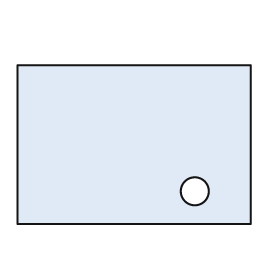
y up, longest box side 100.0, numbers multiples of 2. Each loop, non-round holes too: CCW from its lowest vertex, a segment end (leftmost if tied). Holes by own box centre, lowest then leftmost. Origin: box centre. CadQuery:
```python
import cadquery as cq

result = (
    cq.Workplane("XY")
    .moveTo(-50.0, -34.0)
    .lineTo(50.0, -34.0)
    .lineTo(50.0, 34.0)
    .lineTo(-50.0, 34.0)
    .close()
    .moveTo(26.0, -20.0)
    .circle(6.0)
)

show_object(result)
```